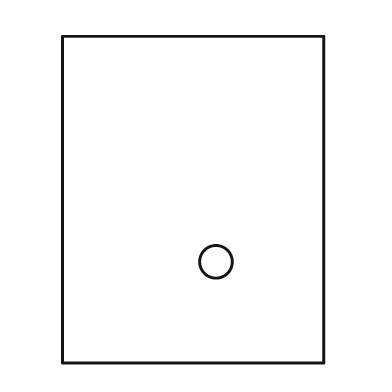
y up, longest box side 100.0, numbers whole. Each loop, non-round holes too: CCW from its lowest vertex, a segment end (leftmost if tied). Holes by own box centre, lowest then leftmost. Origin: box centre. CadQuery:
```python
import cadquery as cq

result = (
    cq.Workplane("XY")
    .moveTo(-40.0, -50.0)
    .lineTo(40.0, -50.0)
    .lineTo(40.0, 50.0)
    .lineTo(-40.0, 50.0)
    .close()
    .moveTo(7.0, -19.0)
    .circle(5.0)
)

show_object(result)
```